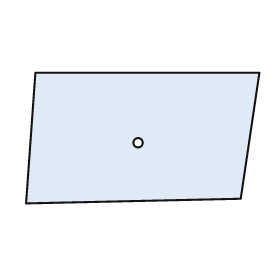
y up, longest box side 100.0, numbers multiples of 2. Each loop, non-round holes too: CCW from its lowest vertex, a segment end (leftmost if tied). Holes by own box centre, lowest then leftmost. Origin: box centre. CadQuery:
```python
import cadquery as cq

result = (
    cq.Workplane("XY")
    .moveTo(-50.0, -28.0)
    .lineTo(42.0, -26.0)
    .lineTo(50.0, 28.0)
    .lineTo(-46.0, 28.0)
    .close()
    .moveTo(-2.0, -2.0)
    .circle(2.0)
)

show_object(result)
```